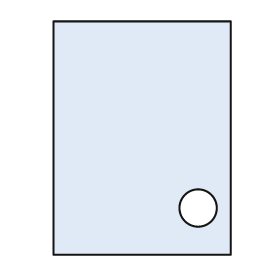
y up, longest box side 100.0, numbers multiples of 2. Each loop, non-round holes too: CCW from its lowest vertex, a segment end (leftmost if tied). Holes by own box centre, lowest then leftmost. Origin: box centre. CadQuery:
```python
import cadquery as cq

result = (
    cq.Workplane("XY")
    .moveTo(-38.0, -50.0)
    .lineTo(38.0, -50.0)
    .lineTo(38.0, 50.0)
    .lineTo(-38.0, 50.0)
    .close()
    .moveTo(24.0, -30.0)
    .circle(8.0)
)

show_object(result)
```